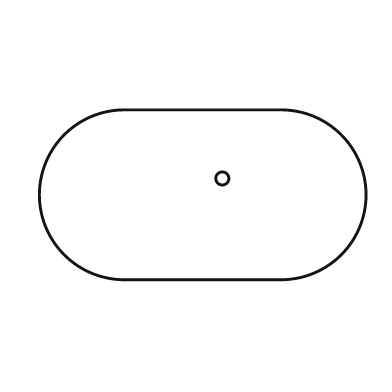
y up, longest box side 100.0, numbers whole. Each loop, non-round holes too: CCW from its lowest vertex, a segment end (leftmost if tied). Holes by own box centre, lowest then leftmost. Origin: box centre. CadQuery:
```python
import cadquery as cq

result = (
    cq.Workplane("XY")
    .moveTo(-24.0, -26.0)
    .lineTo(24.0, -26.0)
    .threePointArc((50.0, 0.0), (24.0, 26.0))
    .lineTo(-24.0, 26.0)
    .threePointArc((-50.0, 0.0), (-24.0, -26.0))
    .close()
    .moveTo(6.0, 5.0)
    .circle(2.0)
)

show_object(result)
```